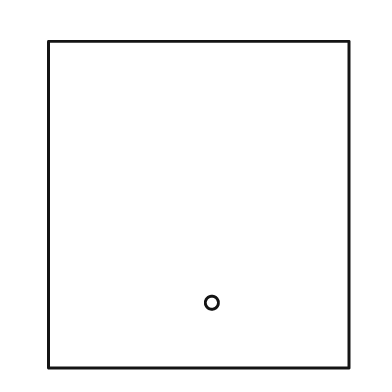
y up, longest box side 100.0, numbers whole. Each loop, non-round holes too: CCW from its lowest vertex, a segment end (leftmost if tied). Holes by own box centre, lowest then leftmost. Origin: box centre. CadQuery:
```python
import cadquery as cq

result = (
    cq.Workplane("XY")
    .moveTo(-46.0, -50.0)
    .lineTo(46.0, -50.0)
    .lineTo(46.0, 50.0)
    .lineTo(-46.0, 50.0)
    .close()
    .moveTo(4.0, -30.0)
    .circle(2.0)
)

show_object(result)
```